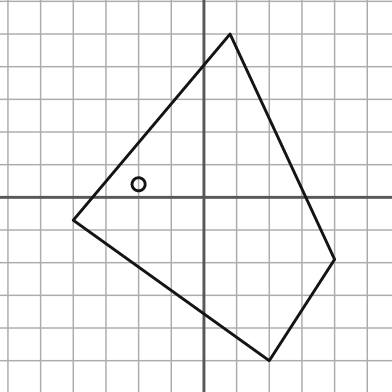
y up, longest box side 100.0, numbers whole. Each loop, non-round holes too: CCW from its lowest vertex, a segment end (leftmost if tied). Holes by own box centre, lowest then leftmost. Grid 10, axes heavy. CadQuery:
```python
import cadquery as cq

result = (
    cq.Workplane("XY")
    .moveTo(20.0, -50.0)
    .lineTo(40.0, -19.0)
    .lineTo(8.0, 50.0)
    .lineTo(-40.0, -7.0)
    .close()
    .moveTo(-20.0, 4.0)
    .circle(2.0)
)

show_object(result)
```